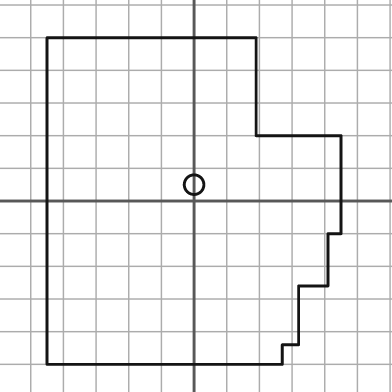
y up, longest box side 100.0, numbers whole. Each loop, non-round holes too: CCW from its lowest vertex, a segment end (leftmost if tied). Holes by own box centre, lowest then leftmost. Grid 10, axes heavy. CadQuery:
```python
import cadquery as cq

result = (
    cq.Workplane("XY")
    .moveTo(-45.0, -50.0)
    .lineTo(27.0, -50.0)
    .lineTo(27.0, -44.0)
    .lineTo(32.0, -44.0)
    .lineTo(32.0, -26.0)
    .lineTo(41.0, -26.0)
    .lineTo(41.0, -10.0)
    .lineTo(45.0, -10.0)
    .lineTo(45.0, 20.0)
    .lineTo(19.0, 20.0)
    .lineTo(19.0, 50.0)
    .lineTo(-45.0, 50.0)
    .close()
    .moveTo(0.0, 5.0)
    .circle(3.0)
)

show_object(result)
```